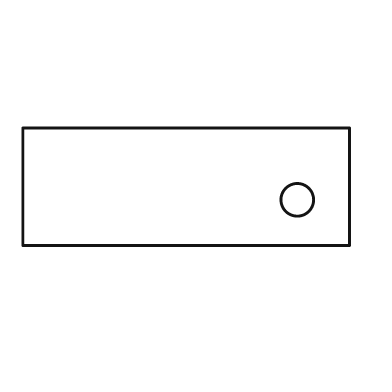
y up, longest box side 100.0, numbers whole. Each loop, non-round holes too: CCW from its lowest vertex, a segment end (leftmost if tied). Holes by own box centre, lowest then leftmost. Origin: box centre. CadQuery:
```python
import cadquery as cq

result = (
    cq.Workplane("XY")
    .moveTo(-50.0, -18.0)
    .lineTo(50.0, -18.0)
    .lineTo(50.0, 18.0)
    .lineTo(-50.0, 18.0)
    .close()
    .moveTo(34.0, -4.0)
    .circle(5.0)
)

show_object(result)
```